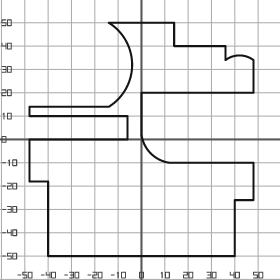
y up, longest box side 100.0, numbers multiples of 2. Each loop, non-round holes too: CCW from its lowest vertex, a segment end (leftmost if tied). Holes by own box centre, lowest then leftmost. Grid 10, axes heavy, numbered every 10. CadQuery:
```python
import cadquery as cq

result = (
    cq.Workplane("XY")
    .moveTo(-40.0, -50.0)
    .lineTo(40.0, -50.0)
    .lineTo(40.0, -26.0)
    .lineTo(48.0, -26.0)
    .lineTo(48.0, -10.0)
    .lineTo(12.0, -10.0)
    .threePointArc((4.0, -6.0), (0.0, 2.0))
    .lineTo(0.0, 20.0)
    .lineTo(48.0, 20.0)
    .lineTo(48.0, 34.0)
    .threePointArc((42.0, 36.0), (36.0, 34.0))
    .lineTo(36.0, 40.0)
    .lineTo(14.0, 40.0)
    .lineTo(14.0, 50.0)
    .lineTo(-14.0, 50.0)
    .threePointArc((-4.0, 32.0), (-14.0, 14.0))
    .lineTo(-48.0, 14.0)
    .lineTo(-48.0, 10.0)
    .lineTo(-6.0, 10.0)
    .lineTo(-6.0, 0.0)
    .lineTo(-48.0, 0.0)
    .lineTo(-48.0, -18.0)
    .lineTo(-40.0, -18.0)
    .close()
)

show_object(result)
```